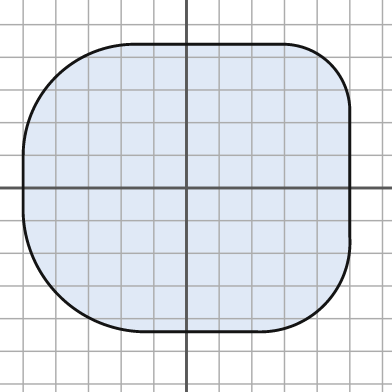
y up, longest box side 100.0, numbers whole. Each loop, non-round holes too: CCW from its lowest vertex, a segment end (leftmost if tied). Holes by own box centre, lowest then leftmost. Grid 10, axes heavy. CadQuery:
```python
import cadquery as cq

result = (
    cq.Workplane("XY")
    .moveTo(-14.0, -44.0)
    .lineTo(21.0, -44.0)
    .threePointArc((42.0, -36.0), (50.0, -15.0))
    .lineTo(50.0, 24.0)
    .threePointArc((44.0, 38.0), (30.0, 44.0))
    .lineTo(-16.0, 44.0)
    .threePointArc((-40.0, 34.0), (-50.0, 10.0))
    .lineTo(-50.0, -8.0)
    .threePointArc((-39.0, -33.0), (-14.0, -44.0))
    .close()
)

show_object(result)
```